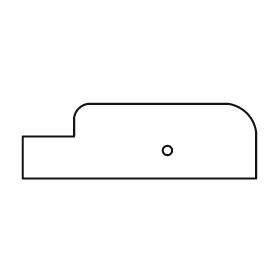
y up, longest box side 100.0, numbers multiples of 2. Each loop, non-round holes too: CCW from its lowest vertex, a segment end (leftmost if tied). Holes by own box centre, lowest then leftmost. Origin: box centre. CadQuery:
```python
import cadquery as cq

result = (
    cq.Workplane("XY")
    .moveTo(-50.0, -16.0)
    .lineTo(50.0, -16.0)
    .lineTo(50.0, 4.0)
    .threePointArc((46.0, 12.0), (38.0, 16.0))
    .lineTo(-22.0, 16.0)
    .threePointArc((-26.0, 14.0), (-28.0, 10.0))
    .lineTo(-28.0, 2.0)
    .lineTo(-50.0, 2.0)
    .close()
    .moveTo(12.0, -4.0)
    .circle(2.0)
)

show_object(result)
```